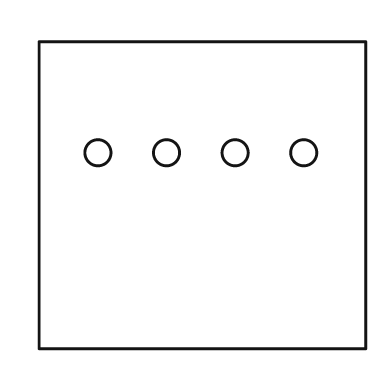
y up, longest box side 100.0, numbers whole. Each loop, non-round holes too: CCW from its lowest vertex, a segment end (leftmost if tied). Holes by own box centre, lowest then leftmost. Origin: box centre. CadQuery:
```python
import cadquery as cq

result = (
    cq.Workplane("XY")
    .moveTo(-50.0, -47.0)
    .lineTo(50.0, -47.0)
    .lineTo(50.0, 47.0)
    .lineTo(-50.0, 47.0)
    .close()
    .moveTo(-32.0, 13.0)
    .circle(4.0)
    .moveTo(-11.0, 13.0)
    .circle(4.0)
    .moveTo(10.0, 13.0)
    .circle(4.0)
    .moveTo(31.0, 13.0)
    .circle(4.0)
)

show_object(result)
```